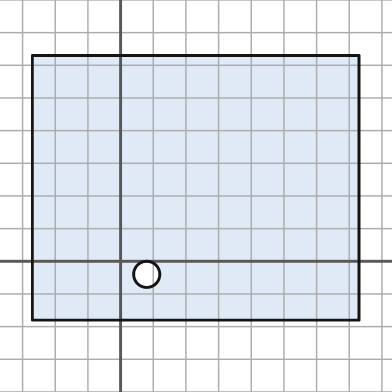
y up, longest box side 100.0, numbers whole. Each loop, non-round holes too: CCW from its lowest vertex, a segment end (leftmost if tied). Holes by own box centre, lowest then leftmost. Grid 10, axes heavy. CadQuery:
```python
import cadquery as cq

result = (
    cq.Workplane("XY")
    .moveTo(-27.0, -18.0)
    .lineTo(73.0, -18.0)
    .lineTo(73.0, 63.0)
    .lineTo(-27.0, 63.0)
    .close()
    .moveTo(8.0, -4.0)
    .circle(4.0)
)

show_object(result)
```